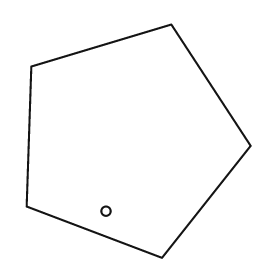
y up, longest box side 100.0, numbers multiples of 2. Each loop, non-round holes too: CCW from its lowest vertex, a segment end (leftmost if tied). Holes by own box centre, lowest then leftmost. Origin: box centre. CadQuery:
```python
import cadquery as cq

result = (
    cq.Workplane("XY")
    .moveTo(10.0, -50.0)
    .lineTo(48.0, -2.0)
    .lineTo(14.0, 50.0)
    .lineTo(-46.0, 32.0)
    .lineTo(-48.0, -28.0)
    .close()
    .moveTo(-14.0, -30.0)
    .circle(2.0)
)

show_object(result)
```